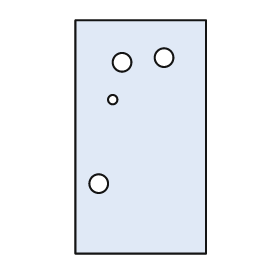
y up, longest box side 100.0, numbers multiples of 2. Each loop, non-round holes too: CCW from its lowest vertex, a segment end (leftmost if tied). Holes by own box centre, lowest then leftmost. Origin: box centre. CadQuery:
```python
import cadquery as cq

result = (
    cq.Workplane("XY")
    .moveTo(-28.0, -50.0)
    .lineTo(28.0, -50.0)
    .lineTo(28.0, 50.0)
    .lineTo(-28.0, 50.0)
    .close()
    .moveTo(-18.0, -20.0)
    .circle(4.0)
    .moveTo(-12.0, 16.0)
    .circle(2.0)
    .moveTo(-8.0, 32.0)
    .circle(4.0)
    .moveTo(10.0, 34.0)
    .circle(4.0)
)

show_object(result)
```